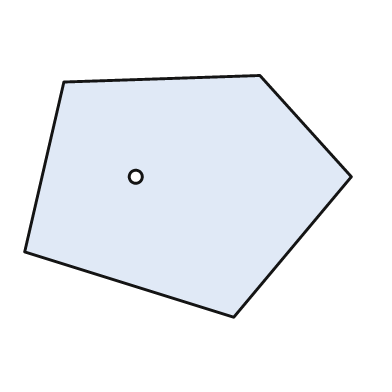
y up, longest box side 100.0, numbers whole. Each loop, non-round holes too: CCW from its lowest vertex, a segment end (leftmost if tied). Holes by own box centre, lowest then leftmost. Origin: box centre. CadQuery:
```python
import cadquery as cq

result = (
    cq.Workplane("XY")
    .moveTo(14.0, -37.0)
    .lineTo(50.0, 6.0)
    .lineTo(22.0, 37.0)
    .lineTo(-38.0, 35.0)
    .lineTo(-50.0, -17.0)
    .close()
    .moveTo(-16.0, 6.0)
    .circle(2.0)
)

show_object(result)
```